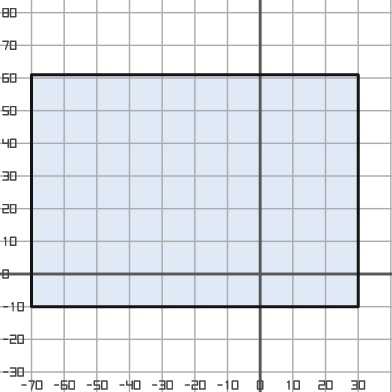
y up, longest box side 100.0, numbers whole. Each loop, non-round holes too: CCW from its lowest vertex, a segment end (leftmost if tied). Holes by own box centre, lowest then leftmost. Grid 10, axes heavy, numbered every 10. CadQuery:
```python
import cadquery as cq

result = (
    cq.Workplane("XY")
    .moveTo(-70.0, -10.0)
    .lineTo(30.0, -10.0)
    .lineTo(30.0, 61.0)
    .lineTo(-70.0, 61.0)
    .close()
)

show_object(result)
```